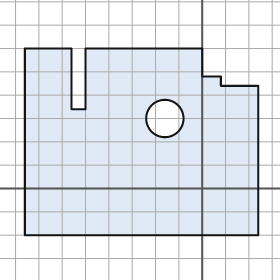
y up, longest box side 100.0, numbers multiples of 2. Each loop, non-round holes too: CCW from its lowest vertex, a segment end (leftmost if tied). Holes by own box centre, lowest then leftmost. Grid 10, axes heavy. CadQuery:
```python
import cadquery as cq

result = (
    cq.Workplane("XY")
    .moveTo(-76.0, -20.0)
    .lineTo(24.0, -20.0)
    .lineTo(24.0, 44.0)
    .lineTo(8.0, 44.0)
    .lineTo(8.0, 48.0)
    .lineTo(0.0, 48.0)
    .lineTo(0.0, 60.0)
    .lineTo(-50.0, 60.0)
    .lineTo(-50.0, 34.0)
    .lineTo(-56.0, 34.0)
    .lineTo(-56.0, 60.0)
    .lineTo(-76.0, 60.0)
    .close()
    .moveTo(-16.0, 30.0)
    .circle(8.0)
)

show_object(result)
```